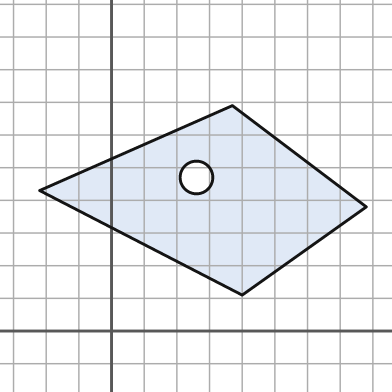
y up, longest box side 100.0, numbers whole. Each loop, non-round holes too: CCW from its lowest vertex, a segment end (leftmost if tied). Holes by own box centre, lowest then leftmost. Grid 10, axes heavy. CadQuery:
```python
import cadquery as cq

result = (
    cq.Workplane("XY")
    .moveTo(40.0, 11.0)
    .lineTo(78.0, 38.0)
    .lineTo(37.0, 69.0)
    .lineTo(-22.0, 43.0)
    .close()
    .moveTo(26.0, 47.0)
    .circle(5.0)
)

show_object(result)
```